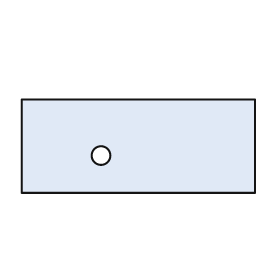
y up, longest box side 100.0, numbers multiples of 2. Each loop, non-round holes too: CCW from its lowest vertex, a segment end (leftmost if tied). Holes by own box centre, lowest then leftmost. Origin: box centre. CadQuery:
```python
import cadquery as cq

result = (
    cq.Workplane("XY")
    .moveTo(-50.0, -20.0)
    .lineTo(50.0, -20.0)
    .lineTo(50.0, 20.0)
    .lineTo(-50.0, 20.0)
    .close()
    .moveTo(-16.0, -4.0)
    .circle(4.0)
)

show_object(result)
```